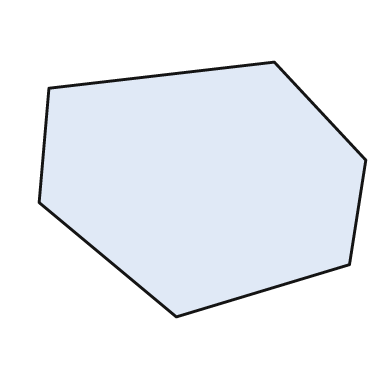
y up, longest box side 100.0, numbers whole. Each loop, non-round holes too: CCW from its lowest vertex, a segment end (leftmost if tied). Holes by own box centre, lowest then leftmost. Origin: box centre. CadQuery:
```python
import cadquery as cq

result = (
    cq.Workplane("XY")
    .moveTo(-8.0, -39.0)
    .lineTo(45.0, -23.0)
    .lineTo(50.0, 9.0)
    .lineTo(22.0, 39.0)
    .lineTo(-47.0, 31.0)
    .lineTo(-50.0, -4.0)
    .close()
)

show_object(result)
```